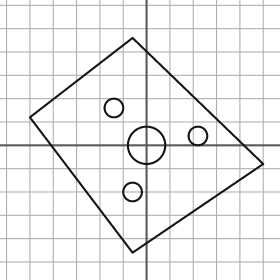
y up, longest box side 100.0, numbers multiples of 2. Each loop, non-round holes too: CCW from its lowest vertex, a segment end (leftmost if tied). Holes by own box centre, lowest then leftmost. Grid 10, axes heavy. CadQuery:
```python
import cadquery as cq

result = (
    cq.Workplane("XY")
    .moveTo(-6.0, -46.0)
    .lineTo(50.0, -8.0)
    .lineTo(-6.0, 46.0)
    .lineTo(-50.0, 12.0)
    .close()
    .moveTo(-6.0, -20.0)
    .circle(4.0)
    .moveTo(0.0, 0.0)
    .circle(8.0)
    .moveTo(22.0, 4.0)
    .circle(4.0)
    .moveTo(-14.0, 16.0)
    .circle(4.0)
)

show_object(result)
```